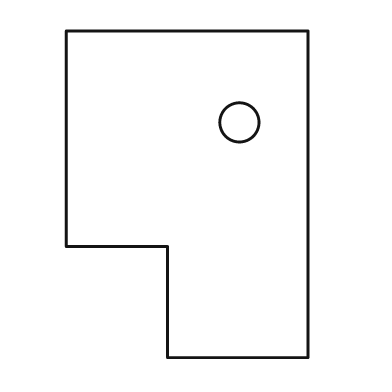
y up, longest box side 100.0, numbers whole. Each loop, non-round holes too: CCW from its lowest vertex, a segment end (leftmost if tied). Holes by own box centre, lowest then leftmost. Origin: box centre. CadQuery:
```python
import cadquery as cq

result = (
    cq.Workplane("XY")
    .moveTo(-6.0, -50.0)
    .lineTo(37.0, -50.0)
    .lineTo(37.0, 50.0)
    .lineTo(-37.0, 50.0)
    .lineTo(-37.0, -16.0)
    .lineTo(-6.0, -16.0)
    .close()
    .moveTo(16.0, 22.0)
    .circle(6.0)
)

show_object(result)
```